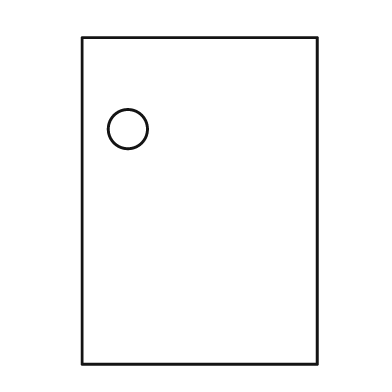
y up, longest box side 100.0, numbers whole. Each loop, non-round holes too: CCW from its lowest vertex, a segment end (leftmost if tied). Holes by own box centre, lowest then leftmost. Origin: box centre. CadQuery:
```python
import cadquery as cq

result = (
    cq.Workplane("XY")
    .moveTo(-36.0, -50.0)
    .lineTo(36.0, -50.0)
    .lineTo(36.0, 50.0)
    .lineTo(-36.0, 50.0)
    .close()
    .moveTo(-22.0, 22.0)
    .circle(6.0)
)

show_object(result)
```